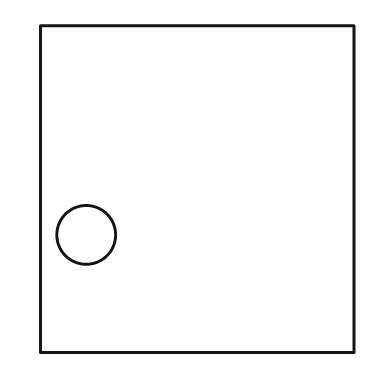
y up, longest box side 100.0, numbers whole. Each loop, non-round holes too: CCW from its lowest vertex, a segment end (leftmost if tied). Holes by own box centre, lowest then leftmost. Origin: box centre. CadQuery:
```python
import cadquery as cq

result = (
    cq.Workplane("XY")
    .moveTo(-48.0, -50.0)
    .lineTo(48.0, -50.0)
    .lineTo(48.0, 50.0)
    .lineTo(-48.0, 50.0)
    .close()
    .moveTo(-34.0, -14.0)
    .circle(9.0)
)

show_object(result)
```